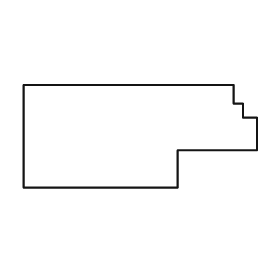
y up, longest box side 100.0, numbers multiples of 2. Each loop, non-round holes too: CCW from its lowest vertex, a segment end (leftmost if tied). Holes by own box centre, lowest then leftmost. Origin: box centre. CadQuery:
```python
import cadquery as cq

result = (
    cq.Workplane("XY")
    .moveTo(-50.0, -22.0)
    .lineTo(16.0, -22.0)
    .lineTo(16.0, -6.0)
    .lineTo(50.0, -6.0)
    .lineTo(50.0, 8.0)
    .lineTo(44.0, 8.0)
    .lineTo(44.0, 14.0)
    .lineTo(40.0, 14.0)
    .lineTo(40.0, 22.0)
    .lineTo(-50.0, 22.0)
    .close()
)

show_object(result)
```